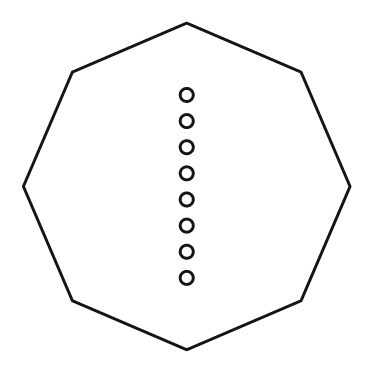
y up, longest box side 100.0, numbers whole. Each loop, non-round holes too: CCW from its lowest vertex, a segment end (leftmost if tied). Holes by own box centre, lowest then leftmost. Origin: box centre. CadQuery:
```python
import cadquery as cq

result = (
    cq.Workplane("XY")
    .moveTo(0.0, -50.0)
    .lineTo(35.0, -35.0)
    .lineTo(50.0, 0.0)
    .lineTo(35.0, 35.0)
    .lineTo(0.0, 50.0)
    .lineTo(-35.0, 35.0)
    .lineTo(-50.0, 0.0)
    .lineTo(-35.0, -35.0)
    .close()
    .moveTo(0.0, -28.0)
    .circle(2.0)
    .moveTo(0.0, -20.0)
    .circle(2.0)
    .moveTo(0.0, -12.0)
    .circle(2.0)
    .moveTo(0.0, -4.0)
    .circle(2.0)
    .moveTo(0.0, 4.0)
    .circle(2.0)
    .moveTo(0.0, 12.0)
    .circle(2.0)
    .moveTo(0.0, 20.0)
    .circle(2.0)
    .moveTo(0.0, 28.0)
    .circle(2.0)
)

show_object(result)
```